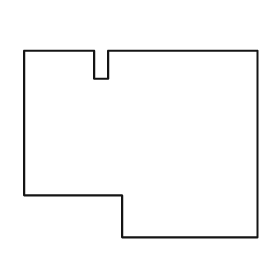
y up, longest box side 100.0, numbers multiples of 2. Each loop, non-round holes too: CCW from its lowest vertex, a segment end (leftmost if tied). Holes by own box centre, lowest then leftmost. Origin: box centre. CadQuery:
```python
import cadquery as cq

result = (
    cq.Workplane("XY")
    .moveTo(-8.0, -40.0)
    .lineTo(50.0, -40.0)
    .lineTo(50.0, 40.0)
    .lineTo(-14.0, 40.0)
    .lineTo(-14.0, 28.0)
    .lineTo(-20.0, 28.0)
    .lineTo(-20.0, 40.0)
    .lineTo(-50.0, 40.0)
    .lineTo(-50.0, -22.0)
    .lineTo(-8.0, -22.0)
    .close()
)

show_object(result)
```